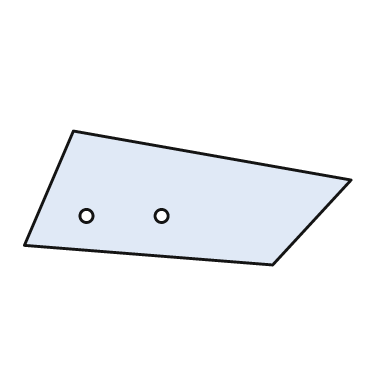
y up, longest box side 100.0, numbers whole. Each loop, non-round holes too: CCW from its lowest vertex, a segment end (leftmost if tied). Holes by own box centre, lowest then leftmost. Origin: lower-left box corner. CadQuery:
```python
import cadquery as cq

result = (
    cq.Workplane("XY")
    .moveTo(76.0, 0.0)
    .lineTo(100.0, 26.0)
    .lineTo(15.0, 41.0)
    .lineTo(0.0, 6.0)
    .close()
    .moveTo(19.0, 15.0)
    .circle(2.0)
    .moveTo(42.0, 15.0)
    .circle(2.0)
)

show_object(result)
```